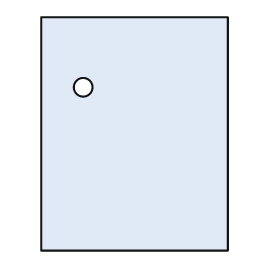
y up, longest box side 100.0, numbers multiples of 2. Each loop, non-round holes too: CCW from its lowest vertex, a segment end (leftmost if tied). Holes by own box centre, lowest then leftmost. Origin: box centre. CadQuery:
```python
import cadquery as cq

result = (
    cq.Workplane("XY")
    .moveTo(-40.0, -50.0)
    .lineTo(40.0, -50.0)
    .lineTo(40.0, 50.0)
    .lineTo(-40.0, 50.0)
    .close()
    .moveTo(-22.0, 20.0)
    .circle(4.0)
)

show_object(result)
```